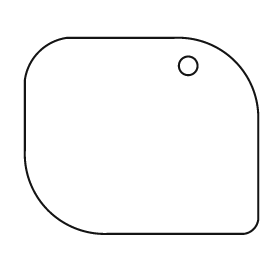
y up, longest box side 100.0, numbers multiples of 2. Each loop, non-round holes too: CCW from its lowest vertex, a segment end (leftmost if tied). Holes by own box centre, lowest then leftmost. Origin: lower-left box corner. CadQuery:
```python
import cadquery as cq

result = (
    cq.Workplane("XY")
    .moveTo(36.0, 0.0)
    .lineTo(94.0, 0.0)
    .threePointArc((98.0, 2.0), (100.0, 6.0))
    .lineTo(100.0, 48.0)
    .threePointArc((90.0, 74.0), (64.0, 84.0))
    .lineTo(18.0, 84.0)
    .threePointArc((6.0, 78.0), (0.0, 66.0))
    .lineTo(0.0, 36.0)
    .threePointArc((10.0, 10.0), (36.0, 0.0))
    .close()
    .moveTo(70.0, 72.0)
    .circle(4.0)
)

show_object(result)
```